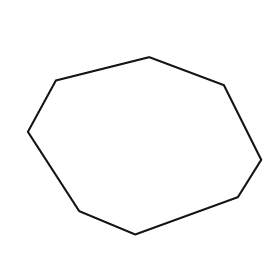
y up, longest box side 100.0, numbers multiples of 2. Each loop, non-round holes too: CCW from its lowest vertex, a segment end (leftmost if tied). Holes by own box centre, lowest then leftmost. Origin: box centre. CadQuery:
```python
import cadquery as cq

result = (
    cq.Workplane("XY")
    .moveTo(-4.0, -38.0)
    .lineTo(40.0, -22.0)
    .lineTo(50.0, -6.0)
    .lineTo(34.0, 26.0)
    .lineTo(2.0, 38.0)
    .lineTo(-38.0, 28.0)
    .lineTo(-50.0, 6.0)
    .lineTo(-28.0, -28.0)
    .close()
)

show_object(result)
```